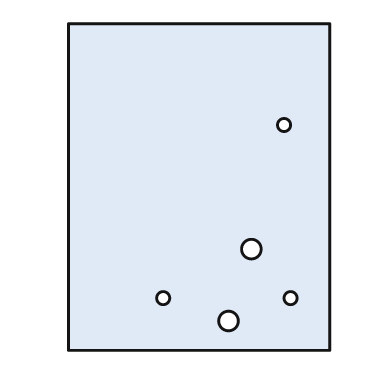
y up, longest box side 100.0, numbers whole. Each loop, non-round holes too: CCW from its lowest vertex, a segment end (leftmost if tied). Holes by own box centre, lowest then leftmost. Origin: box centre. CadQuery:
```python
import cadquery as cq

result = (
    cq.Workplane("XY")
    .moveTo(-40.0, -50.0)
    .lineTo(40.0, -50.0)
    .lineTo(40.0, 50.0)
    .lineTo(-40.0, 50.0)
    .close()
    .moveTo(9.0, -41.0)
    .circle(3.0)
    .moveTo(-11.0, -34.0)
    .circle(2.0)
    .moveTo(28.0, -34.0)
    .circle(2.0)
    .moveTo(16.0, -19.0)
    .circle(3.0)
    .moveTo(26.0, 19.0)
    .circle(2.0)
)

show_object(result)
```